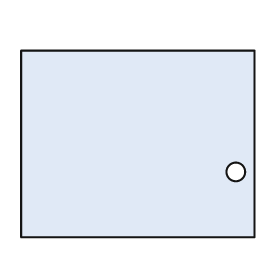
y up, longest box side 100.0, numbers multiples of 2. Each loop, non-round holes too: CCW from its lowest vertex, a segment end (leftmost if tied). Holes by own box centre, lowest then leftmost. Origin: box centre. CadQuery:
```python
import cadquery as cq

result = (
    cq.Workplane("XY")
    .moveTo(-50.0, -40.0)
    .lineTo(50.0, -40.0)
    .lineTo(50.0, 40.0)
    .lineTo(-50.0, 40.0)
    .close()
    .moveTo(42.0, -12.0)
    .circle(4.0)
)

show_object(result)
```